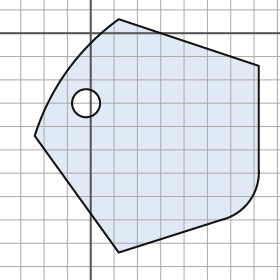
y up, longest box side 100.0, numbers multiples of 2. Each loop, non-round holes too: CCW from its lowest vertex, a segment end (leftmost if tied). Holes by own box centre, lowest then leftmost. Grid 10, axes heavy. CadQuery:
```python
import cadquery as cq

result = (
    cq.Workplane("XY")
    .moveTo(12.0, -94.0)
    .lineTo(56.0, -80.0)
    .threePointArc((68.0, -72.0), (72.0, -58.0))
    .lineTo(72.0, -14.0)
    .lineTo(12.0, 6.0)
    .threePointArc((-10.0, -16.0), (-24.0, -44.0))
    .close()
    .moveTo(-2.0, -30.0)
    .circle(6.0)
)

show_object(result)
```